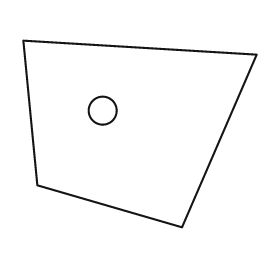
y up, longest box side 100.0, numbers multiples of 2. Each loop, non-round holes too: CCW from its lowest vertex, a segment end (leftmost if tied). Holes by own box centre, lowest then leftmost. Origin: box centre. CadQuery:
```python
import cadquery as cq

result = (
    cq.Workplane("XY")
    .moveTo(18.0, -40.0)
    .lineTo(50.0, 34.0)
    .lineTo(-50.0, 40.0)
    .lineTo(-44.0, -22.0)
    .close()
    .moveTo(-16.0, 10.0)
    .circle(6.0)
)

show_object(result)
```